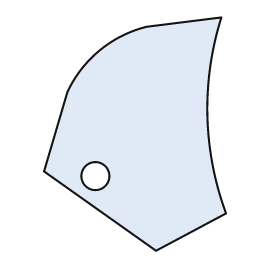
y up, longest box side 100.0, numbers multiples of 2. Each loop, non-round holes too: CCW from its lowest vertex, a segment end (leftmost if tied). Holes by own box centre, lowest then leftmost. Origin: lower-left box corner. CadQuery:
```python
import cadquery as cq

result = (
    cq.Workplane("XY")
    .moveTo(48.0, 0.0)
    .lineTo(78.0, 16.0)
    .threePointArc((70.0, 58.0), (76.0, 100.0))
    .lineTo(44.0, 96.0)
    .threePointArc((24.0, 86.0), (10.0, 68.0))
    .lineTo(0.0, 34.0)
    .close()
    .moveTo(22.0, 32.0)
    .circle(6.0)
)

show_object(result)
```